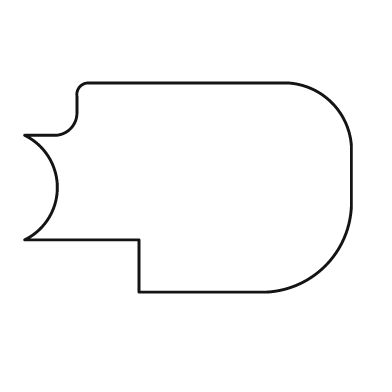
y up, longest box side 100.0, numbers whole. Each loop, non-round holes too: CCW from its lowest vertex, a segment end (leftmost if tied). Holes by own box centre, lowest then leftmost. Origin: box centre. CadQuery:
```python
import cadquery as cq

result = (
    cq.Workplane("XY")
    .moveTo(-15.0, -32.0)
    .lineTo(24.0, -32.0)
    .threePointArc((42.0, -24.0), (50.0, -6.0))
    .lineTo(50.0, 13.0)
    .threePointArc((44.0, 26.0), (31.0, 32.0))
    .lineTo(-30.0, 32.0)
    .threePointArc((-33.0, 31.0), (-34.0, 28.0))
    .lineTo(-34.0, 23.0)
    .threePointArc((-36.0, 18.0), (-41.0, 16.0))
    .lineTo(-50.0, 16.0)
    .threePointArc((-40.0, 0.0), (-50.0, -16.0))
    .lineTo(-15.0, -16.0)
    .close()
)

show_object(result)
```